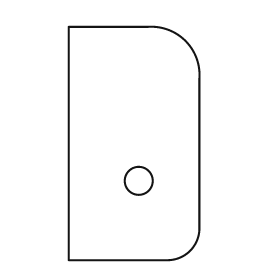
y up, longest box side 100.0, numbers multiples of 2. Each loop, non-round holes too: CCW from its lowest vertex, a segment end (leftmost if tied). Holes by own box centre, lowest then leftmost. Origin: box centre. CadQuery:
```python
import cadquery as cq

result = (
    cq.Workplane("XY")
    .moveTo(-28.0, -50.0)
    .lineTo(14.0, -50.0)
    .threePointArc((24.0, -46.0), (28.0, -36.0))
    .lineTo(28.0, 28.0)
    .threePointArc((22.0, 44.0), (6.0, 50.0))
    .lineTo(-28.0, 50.0)
    .close()
    .moveTo(2.0, -16.0)
    .circle(6.0)
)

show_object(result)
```